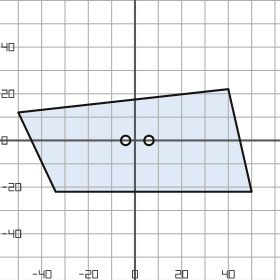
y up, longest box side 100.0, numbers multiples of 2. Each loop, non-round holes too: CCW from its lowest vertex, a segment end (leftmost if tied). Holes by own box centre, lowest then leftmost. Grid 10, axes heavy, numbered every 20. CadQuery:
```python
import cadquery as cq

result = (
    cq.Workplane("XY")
    .moveTo(-34.0, -22.0)
    .lineTo(50.0, -22.0)
    .lineTo(40.0, 22.0)
    .lineTo(-50.0, 12.0)
    .close()
    .moveTo(-4.0, 0.0)
    .circle(2.0)
    .moveTo(6.0, 0.0)
    .circle(2.0)
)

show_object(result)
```